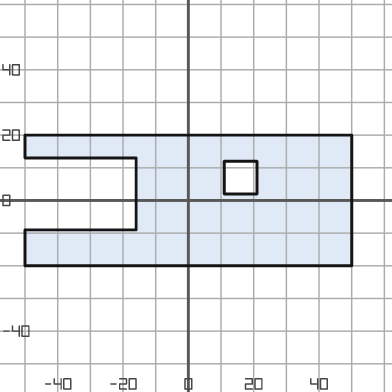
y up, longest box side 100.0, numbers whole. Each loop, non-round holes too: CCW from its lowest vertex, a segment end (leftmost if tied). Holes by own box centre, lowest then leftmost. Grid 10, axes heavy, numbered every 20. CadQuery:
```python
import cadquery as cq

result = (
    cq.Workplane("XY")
    .moveTo(-50.0, -20.0)
    .lineTo(50.0, -20.0)
    .lineTo(50.0, 20.0)
    .lineTo(-50.0, 20.0)
    .lineTo(-50.0, 13.0)
    .lineTo(-16.0, 13.0)
    .lineTo(-16.0, -9.0)
    .lineTo(-50.0, -9.0)
    .close()
    .moveTo(11.0, 2.0)
    .lineTo(21.0, 2.0)
    .lineTo(21.0, 12.0)
    .lineTo(11.0, 12.0)
    .close()
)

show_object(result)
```